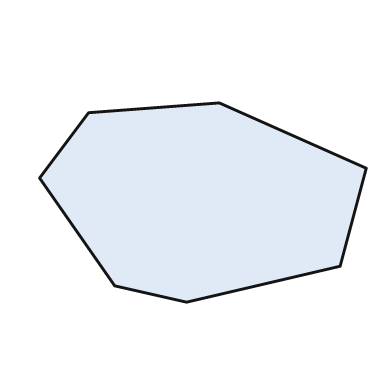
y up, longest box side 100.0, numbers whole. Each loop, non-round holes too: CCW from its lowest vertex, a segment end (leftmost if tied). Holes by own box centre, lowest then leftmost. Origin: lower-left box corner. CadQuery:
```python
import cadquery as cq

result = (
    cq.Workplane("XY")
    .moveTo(45.0, 0.0)
    .lineTo(92.0, 11.0)
    .lineTo(100.0, 41.0)
    .lineTo(55.0, 61.0)
    .lineTo(15.0, 58.0)
    .lineTo(0.0, 38.0)
    .lineTo(23.0, 5.0)
    .close()
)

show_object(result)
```